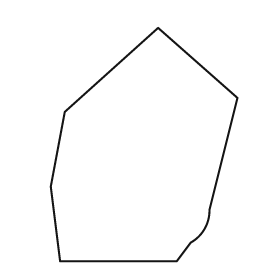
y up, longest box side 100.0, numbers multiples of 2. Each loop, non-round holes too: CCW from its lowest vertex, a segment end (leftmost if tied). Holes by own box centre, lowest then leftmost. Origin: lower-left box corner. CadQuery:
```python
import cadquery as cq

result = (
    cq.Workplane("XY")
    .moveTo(4.0, 0.0)
    .lineTo(54.0, 0.0)
    .lineTo(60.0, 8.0)
    .threePointArc((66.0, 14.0), (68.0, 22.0))
    .lineTo(80.0, 70.0)
    .lineTo(46.0, 100.0)
    .lineTo(6.0, 64.0)
    .lineTo(0.0, 32.0)
    .close()
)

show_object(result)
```